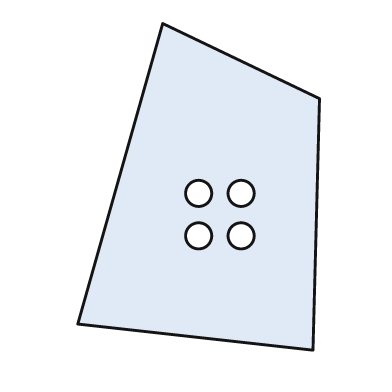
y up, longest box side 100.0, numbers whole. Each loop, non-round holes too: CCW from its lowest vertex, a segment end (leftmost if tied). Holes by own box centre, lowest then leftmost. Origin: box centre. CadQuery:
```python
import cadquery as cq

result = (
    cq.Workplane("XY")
    .moveTo(35.0, -50.0)
    .lineTo(37.0, 27.0)
    .lineTo(-11.0, 50.0)
    .lineTo(-37.0, -42.0)
    .close()
    .moveTo(0.0, -15.0)
    .circle(4.0)
    .moveTo(13.0, -15.0)
    .circle(4.0)
    .moveTo(0.0, -2.0)
    .circle(4.0)
    .moveTo(13.0, -2.0)
    .circle(4.0)
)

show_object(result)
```